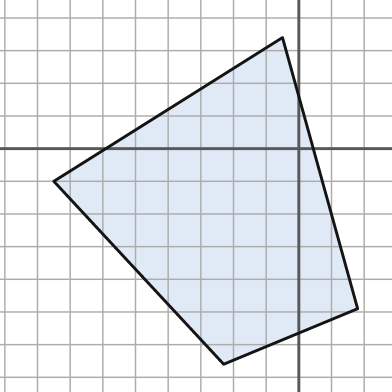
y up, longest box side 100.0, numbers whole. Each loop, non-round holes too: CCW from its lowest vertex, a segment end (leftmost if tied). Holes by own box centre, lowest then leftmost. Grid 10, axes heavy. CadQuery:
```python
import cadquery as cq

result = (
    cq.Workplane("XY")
    .moveTo(-23.0, -66.0)
    .lineTo(18.0, -49.0)
    .lineTo(-5.0, 34.0)
    .lineTo(-75.0, -10.0)
    .close()
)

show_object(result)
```